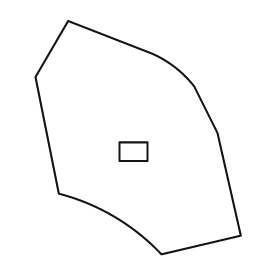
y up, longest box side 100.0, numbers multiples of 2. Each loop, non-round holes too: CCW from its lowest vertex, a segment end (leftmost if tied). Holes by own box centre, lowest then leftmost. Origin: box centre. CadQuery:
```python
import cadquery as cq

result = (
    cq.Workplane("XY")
    .moveTo(10.0, -50.0)
    .lineTo(44.0, -42.0)
    .lineTo(34.0, 2.0)
    .lineTo(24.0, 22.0)
    .threePointArc((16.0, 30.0), (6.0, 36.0))
    .lineTo(-30.0, 50.0)
    .lineTo(-44.0, 26.0)
    .lineTo(-34.0, -24.0)
    .threePointArc((-10.0, -34.0), (10.0, -50.0))
    .close()
    .moveTo(-8.0, -10.0)
    .lineTo(4.0, -10.0)
    .lineTo(4.0, -2.0)
    .lineTo(-8.0, -2.0)
    .close()
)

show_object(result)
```